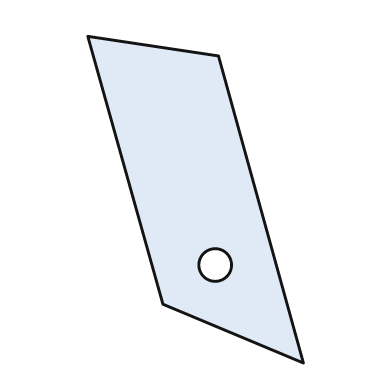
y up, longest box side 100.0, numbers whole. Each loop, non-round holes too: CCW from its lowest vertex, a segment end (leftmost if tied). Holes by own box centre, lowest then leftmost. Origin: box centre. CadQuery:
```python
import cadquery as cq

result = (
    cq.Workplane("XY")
    .moveTo(33.0, -50.0)
    .lineTo(7.0, 44.0)
    .lineTo(-33.0, 50.0)
    .lineTo(-10.0, -32.0)
    .close()
    .moveTo(6.0, -20.0)
    .circle(5.0)
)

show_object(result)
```